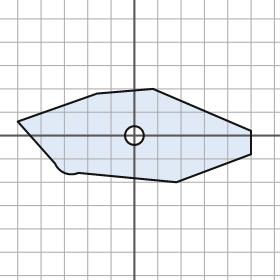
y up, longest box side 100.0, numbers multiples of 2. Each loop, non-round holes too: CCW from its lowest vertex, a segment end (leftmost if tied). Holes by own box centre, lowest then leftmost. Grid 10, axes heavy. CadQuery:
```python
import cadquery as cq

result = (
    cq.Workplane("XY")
    .moveTo(18.0, -20.0)
    .lineTo(50.0, -8.0)
    .lineTo(50.0, 2.0)
    .lineTo(8.0, 20.0)
    .lineTo(-16.0, 18.0)
    .lineTo(-50.0, 6.0)
    .lineTo(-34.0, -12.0)
    .threePointArc((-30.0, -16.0), (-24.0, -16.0))
    .close()
    .moveTo(0.0, 0.0)
    .circle(4.0)
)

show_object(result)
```